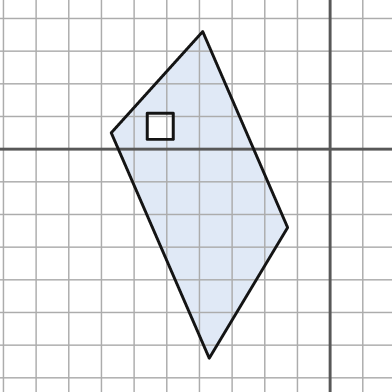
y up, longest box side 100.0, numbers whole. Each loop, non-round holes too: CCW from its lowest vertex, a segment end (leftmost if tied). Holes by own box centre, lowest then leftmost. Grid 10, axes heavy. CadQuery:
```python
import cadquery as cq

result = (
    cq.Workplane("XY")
    .moveTo(-37.0, -64.0)
    .lineTo(-13.0, -24.0)
    .lineTo(-39.0, 36.0)
    .lineTo(-67.0, 5.0)
    .close()
    .moveTo(-56.0, 3.0)
    .lineTo(-48.0, 3.0)
    .lineTo(-48.0, 11.0)
    .lineTo(-56.0, 11.0)
    .close()
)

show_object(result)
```